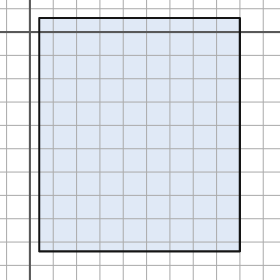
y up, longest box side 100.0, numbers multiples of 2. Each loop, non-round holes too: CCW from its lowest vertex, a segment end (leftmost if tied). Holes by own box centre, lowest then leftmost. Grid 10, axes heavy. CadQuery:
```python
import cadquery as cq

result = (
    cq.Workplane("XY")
    .moveTo(4.0, -94.0)
    .lineTo(90.0, -94.0)
    .lineTo(90.0, 6.0)
    .lineTo(4.0, 6.0)
    .close()
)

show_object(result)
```